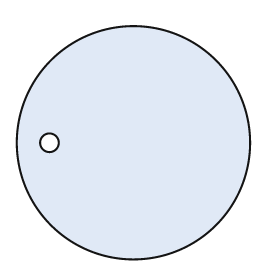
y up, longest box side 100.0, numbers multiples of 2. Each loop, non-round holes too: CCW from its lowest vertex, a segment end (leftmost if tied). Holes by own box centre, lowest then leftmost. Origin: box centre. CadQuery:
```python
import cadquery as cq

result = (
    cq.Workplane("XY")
    .moveTo(0.0, 0.0)
    .circle(50.0)
    .moveTo(-36.0, 0.0)
    .circle(4.0)
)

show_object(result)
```